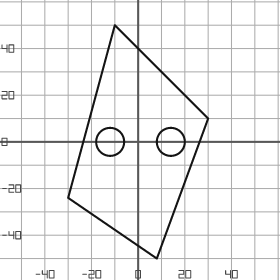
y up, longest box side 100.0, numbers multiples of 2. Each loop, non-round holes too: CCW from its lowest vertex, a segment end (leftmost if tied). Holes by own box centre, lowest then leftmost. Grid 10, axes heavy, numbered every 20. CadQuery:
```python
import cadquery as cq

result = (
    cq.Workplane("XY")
    .moveTo(8.0, -50.0)
    .lineTo(30.0, 10.0)
    .lineTo(-10.0, 50.0)
    .lineTo(-30.0, -24.0)
    .close()
    .moveTo(-12.0, 0.0)
    .circle(6.0)
    .moveTo(14.0, 0.0)
    .circle(6.0)
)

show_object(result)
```